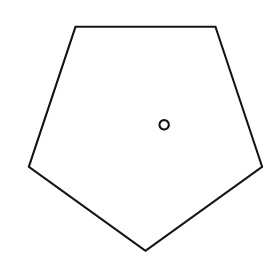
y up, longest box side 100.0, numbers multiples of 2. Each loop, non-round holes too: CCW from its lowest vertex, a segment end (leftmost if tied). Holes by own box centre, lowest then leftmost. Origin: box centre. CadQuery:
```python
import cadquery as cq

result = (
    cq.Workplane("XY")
    .moveTo(0.0, -48.0)
    .lineTo(50.0, -12.0)
    .lineTo(30.0, 48.0)
    .lineTo(-30.0, 48.0)
    .lineTo(-50.0, -12.0)
    .close()
    .moveTo(8.0, 6.0)
    .circle(2.0)
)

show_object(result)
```